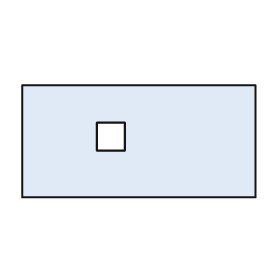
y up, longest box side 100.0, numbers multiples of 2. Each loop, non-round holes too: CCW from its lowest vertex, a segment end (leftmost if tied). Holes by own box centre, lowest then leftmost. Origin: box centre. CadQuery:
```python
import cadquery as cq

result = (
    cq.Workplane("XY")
    .moveTo(-50.0, -24.0)
    .lineTo(50.0, -24.0)
    .lineTo(50.0, 24.0)
    .lineTo(-50.0, 24.0)
    .close()
    .moveTo(-18.0, -4.0)
    .lineTo(-6.0, -4.0)
    .lineTo(-6.0, 8.0)
    .lineTo(-18.0, 8.0)
    .close()
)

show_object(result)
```